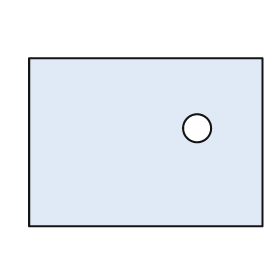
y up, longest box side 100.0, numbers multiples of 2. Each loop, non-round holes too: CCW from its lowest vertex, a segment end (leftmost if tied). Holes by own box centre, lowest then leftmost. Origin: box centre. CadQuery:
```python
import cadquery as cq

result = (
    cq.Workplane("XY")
    .moveTo(-50.0, -36.0)
    .lineTo(50.0, -36.0)
    .lineTo(50.0, 36.0)
    .lineTo(-50.0, 36.0)
    .close()
    .moveTo(22.0, 6.0)
    .circle(6.0)
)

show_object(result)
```